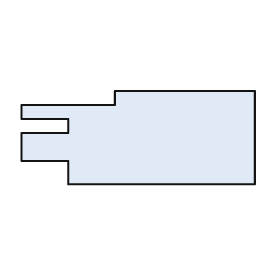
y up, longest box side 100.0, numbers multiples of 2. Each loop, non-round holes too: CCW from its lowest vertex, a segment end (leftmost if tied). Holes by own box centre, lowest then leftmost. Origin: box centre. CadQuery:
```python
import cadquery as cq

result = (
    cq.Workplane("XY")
    .moveTo(-30.0, -20.0)
    .lineTo(50.0, -20.0)
    .lineTo(50.0, 20.0)
    .lineTo(-10.0, 20.0)
    .lineTo(-10.0, 14.0)
    .lineTo(-50.0, 14.0)
    .lineTo(-50.0, 8.0)
    .lineTo(-30.0, 8.0)
    .lineTo(-30.0, 2.0)
    .lineTo(-50.0, 2.0)
    .lineTo(-50.0, -10.0)
    .lineTo(-30.0, -10.0)
    .close()
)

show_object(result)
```